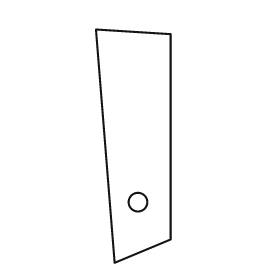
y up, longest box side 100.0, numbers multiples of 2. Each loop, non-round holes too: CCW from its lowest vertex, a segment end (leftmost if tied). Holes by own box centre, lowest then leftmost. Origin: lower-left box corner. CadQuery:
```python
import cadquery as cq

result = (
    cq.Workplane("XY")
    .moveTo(8.0, 0.0)
    .lineTo(32.0, 10.0)
    .lineTo(32.0, 98.0)
    .lineTo(0.0, 100.0)
    .close()
    .moveTo(18.0, 26.0)
    .circle(4.0)
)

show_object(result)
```